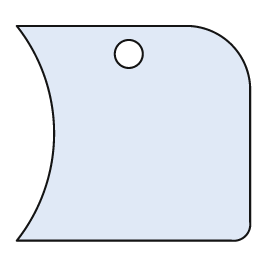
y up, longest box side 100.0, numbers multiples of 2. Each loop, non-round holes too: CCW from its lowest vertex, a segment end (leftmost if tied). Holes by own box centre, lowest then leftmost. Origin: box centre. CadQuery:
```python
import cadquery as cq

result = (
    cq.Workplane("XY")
    .moveTo(-50.0, -46.0)
    .lineTo(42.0, -46.0)
    .threePointArc((48.0, -44.0), (50.0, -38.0))
    .lineTo(50.0, 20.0)
    .threePointArc((42.0, 38.0), (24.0, 46.0))
    .lineTo(-50.0, 46.0)
    .threePointArc((-34.0, 0.0), (-50.0, -46.0))
    .close()
    .moveTo(-2.0, 34.0)
    .circle(6.0)
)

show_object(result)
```